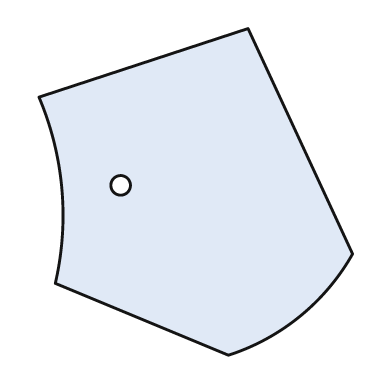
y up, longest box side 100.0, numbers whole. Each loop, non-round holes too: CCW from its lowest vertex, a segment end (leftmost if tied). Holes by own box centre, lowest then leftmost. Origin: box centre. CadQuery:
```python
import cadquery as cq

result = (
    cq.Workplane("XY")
    .moveTo(10.0, -50.0)
    .threePointArc((32.0, -38.0), (48.0, -19.0))
    .lineTo(16.0, 50.0)
    .lineTo(-48.0, 29.0)
    .threePointArc((-41.0, 1.0), (-43.0, -28.0))
    .close()
    .moveTo(-23.0, 2.0)
    .circle(3.0)
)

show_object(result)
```